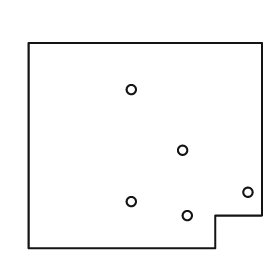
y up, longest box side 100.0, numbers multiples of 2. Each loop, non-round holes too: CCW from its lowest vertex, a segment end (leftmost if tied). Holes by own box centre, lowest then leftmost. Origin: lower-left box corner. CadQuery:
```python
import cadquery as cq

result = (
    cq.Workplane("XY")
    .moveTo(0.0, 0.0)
    .lineTo(80.0, 0.0)
    .lineTo(80.0, 14.0)
    .lineTo(100.0, 14.0)
    .lineTo(100.0, 88.0)
    .lineTo(0.0, 88.0)
    .close()
    .moveTo(68.0, 14.0)
    .circle(2.0)
    .moveTo(44.0, 20.0)
    .circle(2.0)
    .moveTo(94.0, 24.0)
    .circle(2.0)
    .moveTo(66.0, 42.0)
    .circle(2.0)
    .moveTo(44.0, 68.0)
    .circle(2.0)
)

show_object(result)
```